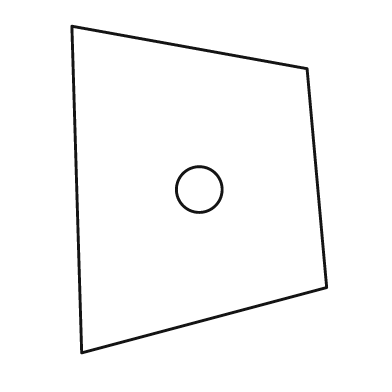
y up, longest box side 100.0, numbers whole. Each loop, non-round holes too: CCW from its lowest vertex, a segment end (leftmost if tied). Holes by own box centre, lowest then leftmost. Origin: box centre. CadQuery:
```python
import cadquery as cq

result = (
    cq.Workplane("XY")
    .moveTo(-36.0, -50.0)
    .lineTo(39.0, -30.0)
    .lineTo(33.0, 37.0)
    .lineTo(-39.0, 50.0)
    .close()
    .moveTo(0.0, 0.0)
    .circle(7.0)
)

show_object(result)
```